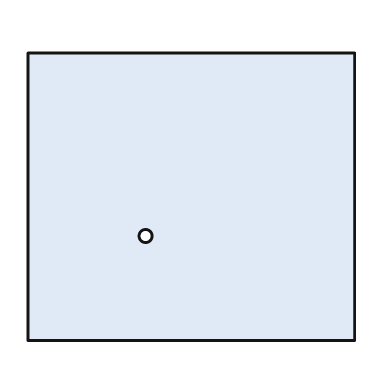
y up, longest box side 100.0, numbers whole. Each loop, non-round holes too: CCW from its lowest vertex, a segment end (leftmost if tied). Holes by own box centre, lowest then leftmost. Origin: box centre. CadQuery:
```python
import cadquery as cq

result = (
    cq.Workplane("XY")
    .moveTo(-50.0, -44.0)
    .lineTo(50.0, -44.0)
    .lineTo(50.0, 44.0)
    .lineTo(-50.0, 44.0)
    .close()
    .moveTo(-14.0, -12.0)
    .circle(2.0)
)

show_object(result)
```